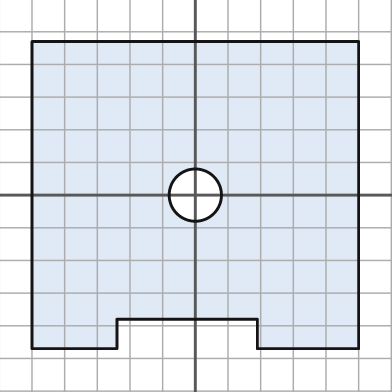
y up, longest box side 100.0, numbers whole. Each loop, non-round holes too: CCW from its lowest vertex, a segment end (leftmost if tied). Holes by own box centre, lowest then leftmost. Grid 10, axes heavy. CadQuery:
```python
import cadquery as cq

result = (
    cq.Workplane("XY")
    .moveTo(-50.0, -47.0)
    .lineTo(-24.0, -47.0)
    .lineTo(-24.0, -38.0)
    .lineTo(19.0, -38.0)
    .lineTo(19.0, -47.0)
    .lineTo(50.0, -47.0)
    .lineTo(50.0, 47.0)
    .lineTo(-50.0, 47.0)
    .close()
    .moveTo(0.0, 0.0)
    .circle(8.0)
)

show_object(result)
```